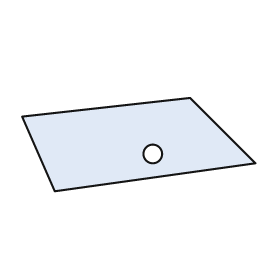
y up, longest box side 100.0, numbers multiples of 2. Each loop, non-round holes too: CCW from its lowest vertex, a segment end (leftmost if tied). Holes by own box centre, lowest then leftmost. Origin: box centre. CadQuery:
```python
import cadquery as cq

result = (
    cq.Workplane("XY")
    .moveTo(-36.0, -20.0)
    .lineTo(50.0, -8.0)
    .lineTo(22.0, 20.0)
    .lineTo(-50.0, 12.0)
    .close()
    .moveTo(6.0, -4.0)
    .circle(4.0)
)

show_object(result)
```